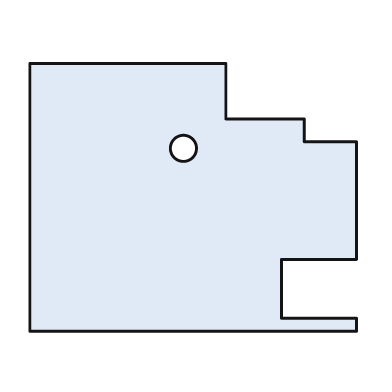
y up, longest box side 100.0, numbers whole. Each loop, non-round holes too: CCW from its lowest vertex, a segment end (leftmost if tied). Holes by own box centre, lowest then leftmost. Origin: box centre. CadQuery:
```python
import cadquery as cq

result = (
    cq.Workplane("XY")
    .moveTo(-50.0, -41.0)
    .lineTo(50.0, -41.0)
    .lineTo(50.0, -37.0)
    .lineTo(27.0, -37.0)
    .lineTo(27.0, -19.0)
    .lineTo(50.0, -19.0)
    .lineTo(50.0, 17.0)
    .lineTo(34.0, 17.0)
    .lineTo(34.0, 24.0)
    .lineTo(10.0, 24.0)
    .lineTo(10.0, 41.0)
    .lineTo(-50.0, 41.0)
    .close()
    .moveTo(-3.0, 15.0)
    .circle(4.0)
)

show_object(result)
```